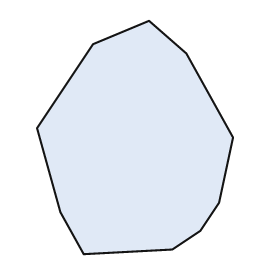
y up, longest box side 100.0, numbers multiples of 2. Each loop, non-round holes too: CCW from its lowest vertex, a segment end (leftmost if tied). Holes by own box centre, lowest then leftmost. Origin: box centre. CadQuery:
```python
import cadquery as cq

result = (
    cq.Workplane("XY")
    .moveTo(-22.0, -50.0)
    .lineTo(16.0, -48.0)
    .lineTo(28.0, -40.0)
    .lineTo(36.0, -28.0)
    .lineTo(42.0, 0.0)
    .lineTo(22.0, 36.0)
    .lineTo(6.0, 50.0)
    .lineTo(-18.0, 40.0)
    .lineTo(-42.0, 4.0)
    .lineTo(-32.0, -32.0)
    .close()
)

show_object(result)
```